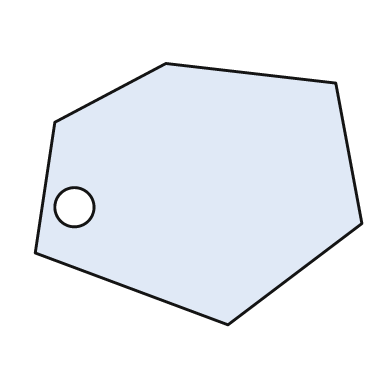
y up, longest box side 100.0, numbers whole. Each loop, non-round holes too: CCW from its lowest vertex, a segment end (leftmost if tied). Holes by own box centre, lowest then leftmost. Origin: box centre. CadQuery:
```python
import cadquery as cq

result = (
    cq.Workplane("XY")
    .moveTo(9.0, -40.0)
    .lineTo(50.0, -9.0)
    .lineTo(42.0, 34.0)
    .lineTo(-10.0, 40.0)
    .lineTo(-44.0, 22.0)
    .lineTo(-50.0, -18.0)
    .close()
    .moveTo(-38.0, -4.0)
    .circle(6.0)
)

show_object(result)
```